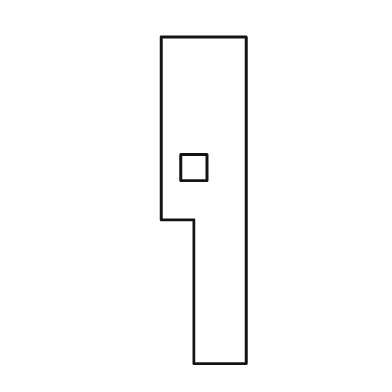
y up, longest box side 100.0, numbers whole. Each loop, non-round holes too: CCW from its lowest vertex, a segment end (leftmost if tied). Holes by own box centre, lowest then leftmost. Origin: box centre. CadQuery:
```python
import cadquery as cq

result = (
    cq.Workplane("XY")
    .moveTo(-3.0, -50.0)
    .lineTo(13.0, -50.0)
    .lineTo(13.0, 50.0)
    .lineTo(-13.0, 50.0)
    .lineTo(-13.0, -6.0)
    .lineTo(-3.0, -6.0)
    .close()
    .moveTo(-7.0, 6.0)
    .lineTo(1.0, 6.0)
    .lineTo(1.0, 14.0)
    .lineTo(-7.0, 14.0)
    .close()
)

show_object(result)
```